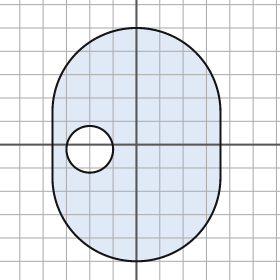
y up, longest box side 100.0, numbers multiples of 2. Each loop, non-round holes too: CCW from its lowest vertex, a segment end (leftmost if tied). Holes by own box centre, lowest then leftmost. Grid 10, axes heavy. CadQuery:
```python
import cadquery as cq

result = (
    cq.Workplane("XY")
    .moveTo(-36.0, -14.0)
    .threePointArc((0.0, -50.0), (36.0, -14.0))
    .lineTo(36.0, 14.0)
    .threePointArc((0.0, 50.0), (-36.0, 14.0))
    .close()
    .moveTo(-20.0, -2.0)
    .circle(10.0)
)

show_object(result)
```